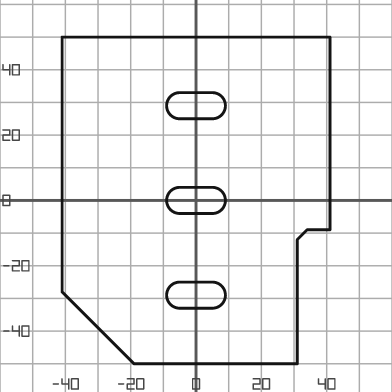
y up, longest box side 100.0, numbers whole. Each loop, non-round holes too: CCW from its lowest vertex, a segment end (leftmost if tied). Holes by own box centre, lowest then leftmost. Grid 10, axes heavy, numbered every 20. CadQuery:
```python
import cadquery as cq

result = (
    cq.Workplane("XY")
    .moveTo(-19.0, -50.0)
    .lineTo(31.0, -50.0)
    .lineTo(31.0, -12.0)
    .lineTo(34.0, -9.0)
    .lineTo(41.0, -9.0)
    .lineTo(41.0, 50.0)
    .lineTo(-41.0, 50.0)
    .lineTo(-41.0, -28.0)
    .close()
    .moveTo(-5.0, -33.0)
    .lineTo(5.0, -33.0)
    .threePointArc((9.0, -29.0), (5.0, -25.0))
    .lineTo(-5.0, -25.0)
    .threePointArc((-9.0, -29.0), (-5.0, -33.0))
    .close()
    .moveTo(-5.0, -4.0)
    .lineTo(5.0, -4.0)
    .threePointArc((9.0, 0.0), (5.0, 4.0))
    .lineTo(-5.0, 4.0)
    .threePointArc((-9.0, 0.0), (-5.0, -4.0))
    .close()
    .moveTo(-5.0, 25.0)
    .lineTo(5.0, 25.0)
    .threePointArc((9.0, 29.0), (5.0, 33.0))
    .lineTo(-5.0, 33.0)
    .threePointArc((-9.0, 29.0), (-5.0, 25.0))
    .close()
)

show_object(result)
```